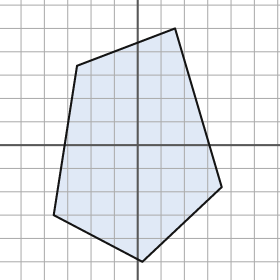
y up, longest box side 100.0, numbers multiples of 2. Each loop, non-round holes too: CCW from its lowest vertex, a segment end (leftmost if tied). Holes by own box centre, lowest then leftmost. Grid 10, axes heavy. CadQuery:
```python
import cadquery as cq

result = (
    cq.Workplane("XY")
    .moveTo(2.0, -50.0)
    .lineTo(36.0, -18.0)
    .lineTo(16.0, 50.0)
    .lineTo(-26.0, 34.0)
    .lineTo(-36.0, -30.0)
    .close()
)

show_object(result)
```